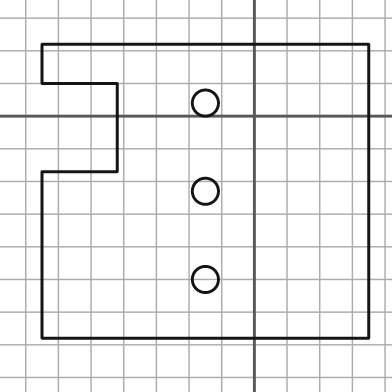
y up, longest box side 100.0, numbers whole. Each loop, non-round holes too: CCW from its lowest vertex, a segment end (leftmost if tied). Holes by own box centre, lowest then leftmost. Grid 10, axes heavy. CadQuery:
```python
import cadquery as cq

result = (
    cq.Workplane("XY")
    .moveTo(-65.0, -68.0)
    .lineTo(35.0, -68.0)
    .lineTo(35.0, 22.0)
    .lineTo(-65.0, 22.0)
    .lineTo(-65.0, 10.0)
    .lineTo(-42.0, 10.0)
    .lineTo(-42.0, -17.0)
    .lineTo(-65.0, -17.0)
    .close()
    .moveTo(-15.0, -50.0)
    .circle(4.0)
    .moveTo(-15.0, -23.0)
    .circle(4.0)
    .moveTo(-15.0, 4.0)
    .circle(4.0)
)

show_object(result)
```